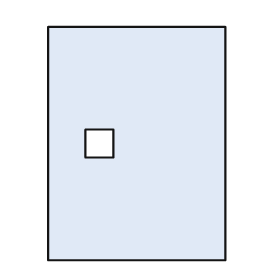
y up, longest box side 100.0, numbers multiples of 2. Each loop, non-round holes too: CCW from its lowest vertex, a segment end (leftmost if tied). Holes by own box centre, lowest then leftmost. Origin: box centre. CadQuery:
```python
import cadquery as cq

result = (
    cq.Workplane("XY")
    .moveTo(-38.0, -50.0)
    .lineTo(38.0, -50.0)
    .lineTo(38.0, 50.0)
    .lineTo(-38.0, 50.0)
    .close()
    .moveTo(-22.0, -6.0)
    .lineTo(-10.0, -6.0)
    .lineTo(-10.0, 6.0)
    .lineTo(-22.0, 6.0)
    .close()
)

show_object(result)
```